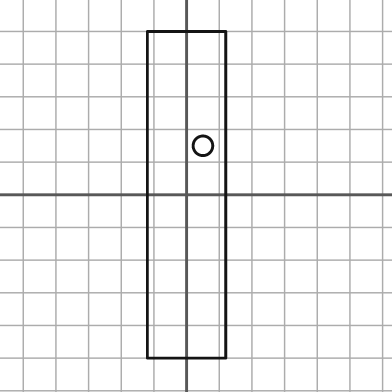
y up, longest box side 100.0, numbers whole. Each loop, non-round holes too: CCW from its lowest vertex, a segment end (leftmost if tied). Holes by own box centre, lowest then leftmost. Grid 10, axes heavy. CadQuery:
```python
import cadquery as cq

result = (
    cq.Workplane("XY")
    .moveTo(-12.0, -50.0)
    .lineTo(12.0, -50.0)
    .lineTo(12.0, 50.0)
    .lineTo(-12.0, 50.0)
    .close()
    .moveTo(5.0, 15.0)
    .circle(3.0)
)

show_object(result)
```